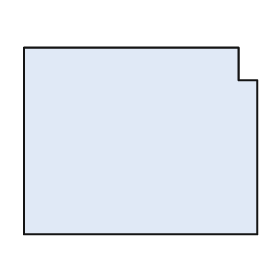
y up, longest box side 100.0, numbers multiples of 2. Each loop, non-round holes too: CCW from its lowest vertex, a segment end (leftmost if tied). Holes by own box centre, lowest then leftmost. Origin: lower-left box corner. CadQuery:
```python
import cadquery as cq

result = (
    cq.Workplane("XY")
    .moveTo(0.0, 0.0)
    .lineTo(100.0, 0.0)
    .lineTo(100.0, 66.0)
    .lineTo(92.0, 66.0)
    .lineTo(92.0, 80.0)
    .lineTo(0.0, 80.0)
    .close()
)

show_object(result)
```